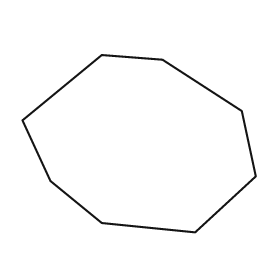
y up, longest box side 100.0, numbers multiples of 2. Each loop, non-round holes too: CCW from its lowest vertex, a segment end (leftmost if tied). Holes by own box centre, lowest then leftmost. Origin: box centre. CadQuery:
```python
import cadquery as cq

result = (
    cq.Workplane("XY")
    .moveTo(24.0, -38.0)
    .lineTo(50.0, -14.0)
    .lineTo(44.0, 14.0)
    .lineTo(10.0, 36.0)
    .lineTo(-16.0, 38.0)
    .lineTo(-50.0, 10.0)
    .lineTo(-38.0, -16.0)
    .lineTo(-16.0, -34.0)
    .close()
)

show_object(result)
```